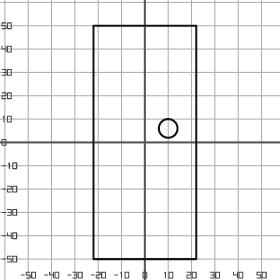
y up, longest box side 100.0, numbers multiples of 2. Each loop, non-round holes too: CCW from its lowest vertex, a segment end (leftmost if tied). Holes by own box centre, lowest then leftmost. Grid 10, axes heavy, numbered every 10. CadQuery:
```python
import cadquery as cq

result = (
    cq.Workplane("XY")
    .moveTo(-22.0, -50.0)
    .lineTo(22.0, -50.0)
    .lineTo(22.0, 50.0)
    .lineTo(-22.0, 50.0)
    .close()
    .moveTo(10.0, 6.0)
    .circle(4.0)
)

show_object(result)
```